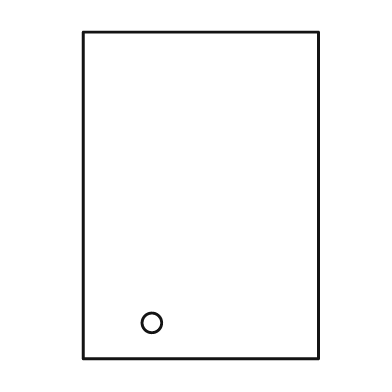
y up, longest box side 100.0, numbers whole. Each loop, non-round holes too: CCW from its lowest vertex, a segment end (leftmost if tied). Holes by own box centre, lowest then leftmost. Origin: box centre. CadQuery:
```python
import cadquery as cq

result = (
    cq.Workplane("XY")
    .moveTo(-36.0, -50.0)
    .lineTo(36.0, -50.0)
    .lineTo(36.0, 50.0)
    .lineTo(-36.0, 50.0)
    .close()
    .moveTo(-15.0, -39.0)
    .circle(3.0)
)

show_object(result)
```